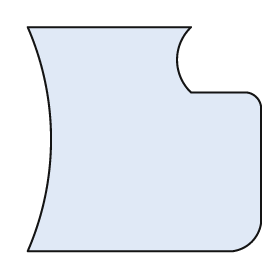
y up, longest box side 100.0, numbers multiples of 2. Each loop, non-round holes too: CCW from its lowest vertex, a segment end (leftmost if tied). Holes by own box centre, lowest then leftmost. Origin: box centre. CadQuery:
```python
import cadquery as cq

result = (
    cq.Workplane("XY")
    .moveTo(-50.0, -48.0)
    .lineTo(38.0, -48.0)
    .threePointArc((46.0, -44.0), (50.0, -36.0))
    .lineTo(50.0, 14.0)
    .threePointArc((48.0, 18.0), (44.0, 20.0))
    .lineTo(20.0, 20.0)
    .threePointArc((14.0, 34.0), (20.0, 48.0))
    .lineTo(-50.0, 48.0)
    .threePointArc((-40.0, 0.0), (-50.0, -48.0))
    .close()
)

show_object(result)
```